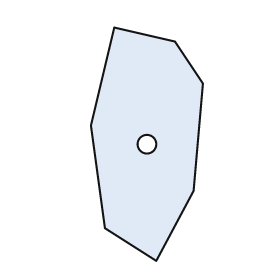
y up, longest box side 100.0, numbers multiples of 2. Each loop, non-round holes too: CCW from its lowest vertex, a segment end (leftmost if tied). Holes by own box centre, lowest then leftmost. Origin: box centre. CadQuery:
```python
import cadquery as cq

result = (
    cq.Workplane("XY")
    .moveTo(4.0, -50.0)
    .lineTo(20.0, -20.0)
    .lineTo(24.0, 26.0)
    .lineTo(12.0, 44.0)
    .lineTo(-14.0, 50.0)
    .lineTo(-24.0, 8.0)
    .lineTo(-18.0, -36.0)
    .close()
    .moveTo(0.0, 0.0)
    .circle(4.0)
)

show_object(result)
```